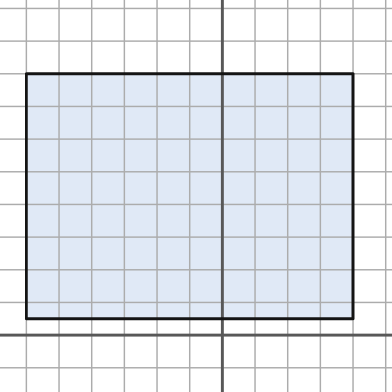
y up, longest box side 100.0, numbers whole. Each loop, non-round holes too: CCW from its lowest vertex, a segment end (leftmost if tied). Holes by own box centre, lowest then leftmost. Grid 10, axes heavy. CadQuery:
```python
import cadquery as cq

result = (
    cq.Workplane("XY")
    .moveTo(-60.0, 5.0)
    .lineTo(40.0, 5.0)
    .lineTo(40.0, 80.0)
    .lineTo(-60.0, 80.0)
    .close()
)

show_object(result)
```